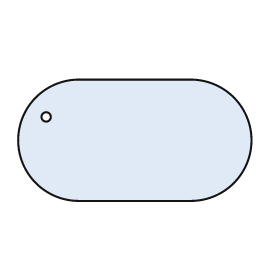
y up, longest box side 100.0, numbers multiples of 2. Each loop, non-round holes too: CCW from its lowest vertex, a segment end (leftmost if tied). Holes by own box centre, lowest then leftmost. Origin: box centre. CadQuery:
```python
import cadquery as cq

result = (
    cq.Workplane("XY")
    .moveTo(-24.0, -26.0)
    .lineTo(24.0, -26.0)
    .threePointArc((50.0, 0.0), (24.0, 26.0))
    .lineTo(-24.0, 26.0)
    .threePointArc((-50.0, 0.0), (-24.0, -26.0))
    .close()
    .moveTo(-38.0, 10.0)
    .circle(2.0)
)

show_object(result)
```